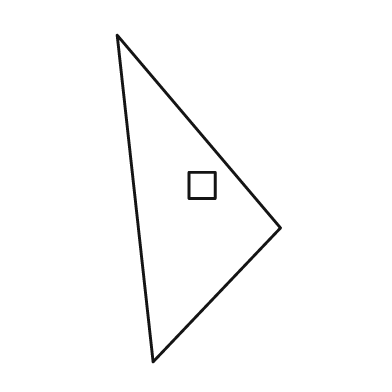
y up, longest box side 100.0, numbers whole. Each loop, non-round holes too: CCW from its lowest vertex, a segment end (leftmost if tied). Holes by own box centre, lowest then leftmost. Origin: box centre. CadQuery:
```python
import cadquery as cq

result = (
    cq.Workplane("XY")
    .moveTo(-14.0, -50.0)
    .lineTo(25.0, -9.0)
    .lineTo(-25.0, 50.0)
    .close()
    .moveTo(-3.0, 0.0)
    .lineTo(5.0, 0.0)
    .lineTo(5.0, 8.0)
    .lineTo(-3.0, 8.0)
    .close()
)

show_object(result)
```